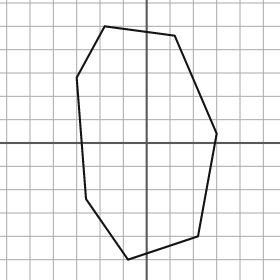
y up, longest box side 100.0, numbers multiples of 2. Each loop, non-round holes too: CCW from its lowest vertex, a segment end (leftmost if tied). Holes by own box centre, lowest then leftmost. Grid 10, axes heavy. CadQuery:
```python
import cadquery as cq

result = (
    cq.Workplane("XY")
    .moveTo(-8.0, -50.0)
    .lineTo(22.0, -40.0)
    .lineTo(30.0, 4.0)
    .lineTo(12.0, 46.0)
    .lineTo(-18.0, 50.0)
    .lineTo(-30.0, 28.0)
    .lineTo(-26.0, -24.0)
    .close()
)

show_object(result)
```